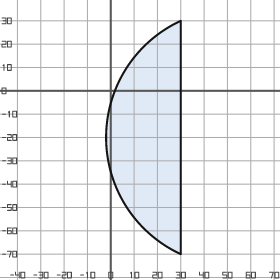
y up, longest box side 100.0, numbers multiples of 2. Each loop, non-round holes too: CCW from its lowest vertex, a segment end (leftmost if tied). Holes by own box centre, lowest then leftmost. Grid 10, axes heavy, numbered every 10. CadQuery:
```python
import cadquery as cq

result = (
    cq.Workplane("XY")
    .moveTo(30.0, -70.0)
    .lineTo(30.0, 30.0)
    .threePointArc((-2.0, -20.0), (30.0, -70.0))
    .close()
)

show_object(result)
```